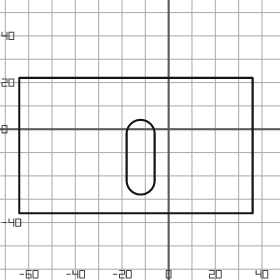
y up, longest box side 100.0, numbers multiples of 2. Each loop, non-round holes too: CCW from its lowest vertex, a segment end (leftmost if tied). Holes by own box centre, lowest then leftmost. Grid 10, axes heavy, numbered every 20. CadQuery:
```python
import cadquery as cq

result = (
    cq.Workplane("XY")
    .moveTo(-64.0, -36.0)
    .lineTo(36.0, -36.0)
    .lineTo(36.0, 22.0)
    .lineTo(-64.0, 22.0)
    .close()
    .moveTo(-18.0, -22.0)
    .threePointArc((-12.0, -28.0), (-6.0, -22.0))
    .lineTo(-6.0, -2.0)
    .threePointArc((-12.0, 4.0), (-18.0, -2.0))
    .close()
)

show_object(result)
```